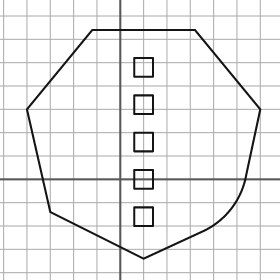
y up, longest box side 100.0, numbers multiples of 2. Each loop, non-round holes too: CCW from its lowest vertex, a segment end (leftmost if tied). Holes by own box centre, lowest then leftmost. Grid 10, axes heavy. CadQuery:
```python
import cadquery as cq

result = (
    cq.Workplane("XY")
    .moveTo(10.0, -34.0)
    .lineTo(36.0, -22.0)
    .threePointArc((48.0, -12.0), (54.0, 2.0))
    .lineTo(60.0, 30.0)
    .lineTo(32.0, 64.0)
    .lineTo(-12.0, 64.0)
    .lineTo(-40.0, 30.0)
    .lineTo(-30.0, -14.0)
    .close()
    .moveTo(6.0, -20.0)
    .lineTo(14.0, -20.0)
    .lineTo(14.0, -12.0)
    .lineTo(6.0, -12.0)
    .close()
    .moveTo(6.0, -4.0)
    .lineTo(14.0, -4.0)
    .lineTo(14.0, 4.0)
    .lineTo(6.0, 4.0)
    .close()
    .moveTo(6.0, 12.0)
    .lineTo(14.0, 12.0)
    .lineTo(14.0, 20.0)
    .lineTo(6.0, 20.0)
    .close()
    .moveTo(6.0, 28.0)
    .lineTo(14.0, 28.0)
    .lineTo(14.0, 36.0)
    .lineTo(6.0, 36.0)
    .close()
    .moveTo(6.0, 44.0)
    .lineTo(14.0, 44.0)
    .lineTo(14.0, 52.0)
    .lineTo(6.0, 52.0)
    .close()
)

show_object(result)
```